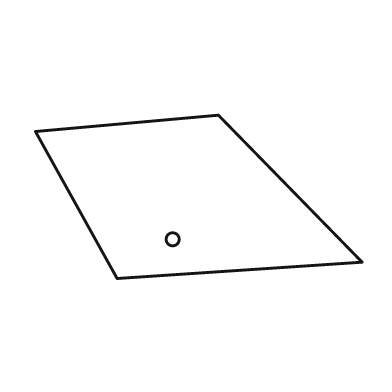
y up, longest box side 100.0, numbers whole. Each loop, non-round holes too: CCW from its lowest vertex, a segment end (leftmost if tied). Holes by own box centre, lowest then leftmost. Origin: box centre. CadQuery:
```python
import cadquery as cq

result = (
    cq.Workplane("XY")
    .moveTo(-25.0, -25.0)
    .lineTo(50.0, -20.0)
    .lineTo(6.0, 25.0)
    .lineTo(-50.0, 20.0)
    .close()
    .moveTo(-8.0, -13.0)
    .circle(2.0)
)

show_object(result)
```